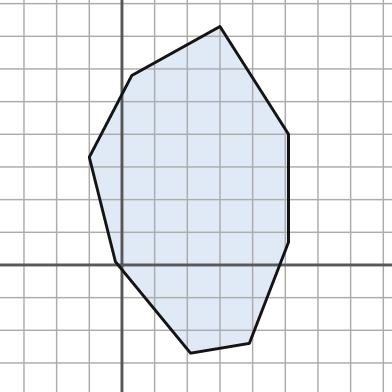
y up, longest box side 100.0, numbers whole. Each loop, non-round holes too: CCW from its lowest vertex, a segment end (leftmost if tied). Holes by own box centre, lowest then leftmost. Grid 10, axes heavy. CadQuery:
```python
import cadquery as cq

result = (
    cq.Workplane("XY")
    .moveTo(21.0, -27.0)
    .lineTo(39.0, -24.0)
    .lineTo(51.0, 7.0)
    .lineTo(51.0, 40.0)
    .lineTo(30.0, 73.0)
    .lineTo(3.0, 58.0)
    .lineTo(-10.0, 33.0)
    .lineTo(-2.0, 1.0)
    .close()
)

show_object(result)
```